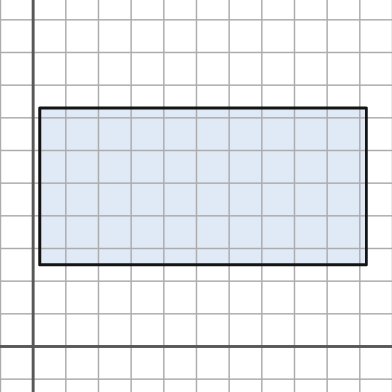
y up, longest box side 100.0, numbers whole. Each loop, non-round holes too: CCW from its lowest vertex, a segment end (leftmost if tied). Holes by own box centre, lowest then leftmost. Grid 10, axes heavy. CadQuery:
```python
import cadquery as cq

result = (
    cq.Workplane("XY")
    .moveTo(2.0, 25.0)
    .lineTo(102.0, 25.0)
    .lineTo(102.0, 73.0)
    .lineTo(2.0, 73.0)
    .close()
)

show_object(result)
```